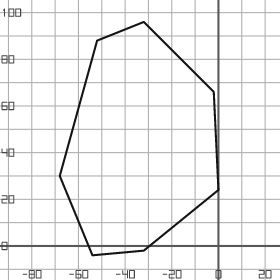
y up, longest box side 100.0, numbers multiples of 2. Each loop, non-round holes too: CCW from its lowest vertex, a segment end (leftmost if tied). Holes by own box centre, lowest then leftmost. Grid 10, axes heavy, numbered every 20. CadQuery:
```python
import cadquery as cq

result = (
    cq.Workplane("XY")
    .moveTo(-54.0, -4.0)
    .lineTo(-32.0, -2.0)
    .lineTo(0.0, 24.0)
    .lineTo(-2.0, 66.0)
    .lineTo(-32.0, 96.0)
    .lineTo(-52.0, 88.0)
    .lineTo(-68.0, 30.0)
    .close()
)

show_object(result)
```